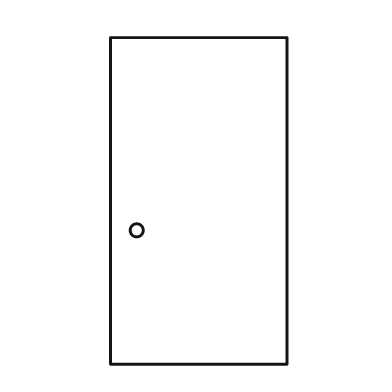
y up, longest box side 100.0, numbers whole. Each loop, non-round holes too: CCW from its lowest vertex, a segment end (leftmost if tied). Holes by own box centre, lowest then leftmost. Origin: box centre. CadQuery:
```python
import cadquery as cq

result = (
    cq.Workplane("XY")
    .moveTo(-27.0, -50.0)
    .lineTo(27.0, -50.0)
    .lineTo(27.0, 50.0)
    .lineTo(-27.0, 50.0)
    .close()
    .moveTo(-19.0, -9.0)
    .circle(2.0)
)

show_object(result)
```